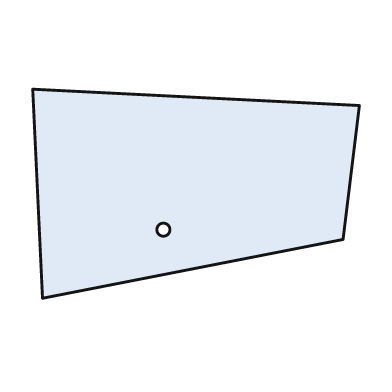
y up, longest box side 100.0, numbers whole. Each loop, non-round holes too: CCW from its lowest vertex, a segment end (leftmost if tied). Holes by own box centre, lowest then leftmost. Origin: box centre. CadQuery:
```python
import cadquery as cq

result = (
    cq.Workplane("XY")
    .moveTo(-47.0, -32.0)
    .lineTo(45.0, -14.0)
    .lineTo(50.0, 27.0)
    .lineTo(-50.0, 32.0)
    .close()
    .moveTo(-10.0, -11.0)
    .circle(2.0)
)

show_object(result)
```